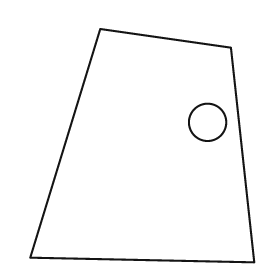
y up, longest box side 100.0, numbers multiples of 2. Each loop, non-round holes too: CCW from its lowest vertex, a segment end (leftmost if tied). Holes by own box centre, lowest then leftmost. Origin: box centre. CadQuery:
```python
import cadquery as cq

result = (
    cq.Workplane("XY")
    .moveTo(48.0, -50.0)
    .lineTo(38.0, 42.0)
    .lineTo(-18.0, 50.0)
    .lineTo(-48.0, -48.0)
    .close()
    .moveTo(28.0, 10.0)
    .circle(8.0)
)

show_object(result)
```